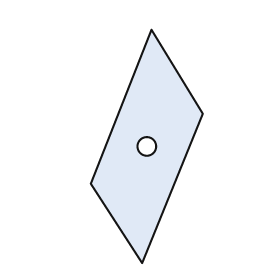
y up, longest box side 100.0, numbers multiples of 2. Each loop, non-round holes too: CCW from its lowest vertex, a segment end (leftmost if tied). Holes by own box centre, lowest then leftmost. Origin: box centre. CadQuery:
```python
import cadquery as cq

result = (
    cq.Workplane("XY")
    .moveTo(-2.0, -50.0)
    .lineTo(24.0, 14.0)
    .lineTo(2.0, 50.0)
    .lineTo(-24.0, -16.0)
    .close()
    .moveTo(0.0, 0.0)
    .circle(4.0)
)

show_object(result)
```